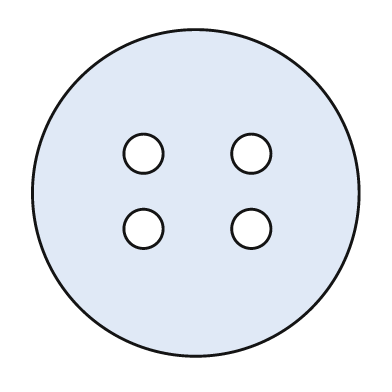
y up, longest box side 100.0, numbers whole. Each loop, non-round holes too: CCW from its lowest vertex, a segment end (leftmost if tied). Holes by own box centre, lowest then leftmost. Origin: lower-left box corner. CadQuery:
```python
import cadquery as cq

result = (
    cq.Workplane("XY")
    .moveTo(50.0, 50.0)
    .circle(50.0)
    .moveTo(34.0, 39.0)
    .circle(6.0)
    .moveTo(67.0, 39.0)
    .circle(6.0)
    .moveTo(34.0, 62.0)
    .circle(6.0)
    .moveTo(67.0, 62.0)
    .circle(6.0)
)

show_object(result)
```